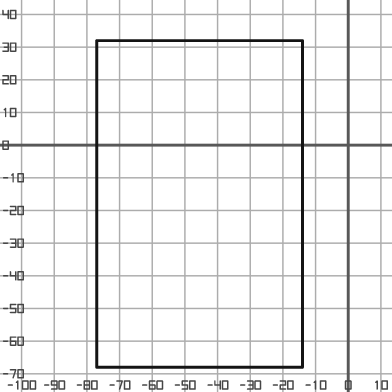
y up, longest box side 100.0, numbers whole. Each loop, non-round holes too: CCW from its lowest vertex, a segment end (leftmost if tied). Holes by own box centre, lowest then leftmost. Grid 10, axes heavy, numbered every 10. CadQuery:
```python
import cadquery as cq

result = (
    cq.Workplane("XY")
    .moveTo(-77.0, -68.0)
    .lineTo(-14.0, -68.0)
    .lineTo(-14.0, 32.0)
    .lineTo(-77.0, 32.0)
    .close()
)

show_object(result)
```